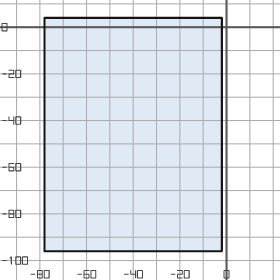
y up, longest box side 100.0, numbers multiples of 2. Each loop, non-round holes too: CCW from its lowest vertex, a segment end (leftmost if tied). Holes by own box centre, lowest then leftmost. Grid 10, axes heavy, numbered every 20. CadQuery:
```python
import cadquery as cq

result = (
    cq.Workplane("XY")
    .moveTo(-78.0, -96.0)
    .lineTo(-2.0, -96.0)
    .lineTo(-2.0, 4.0)
    .lineTo(-78.0, 4.0)
    .close()
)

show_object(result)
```